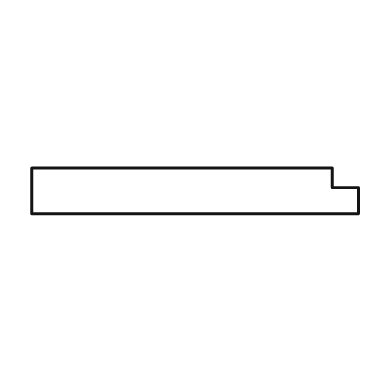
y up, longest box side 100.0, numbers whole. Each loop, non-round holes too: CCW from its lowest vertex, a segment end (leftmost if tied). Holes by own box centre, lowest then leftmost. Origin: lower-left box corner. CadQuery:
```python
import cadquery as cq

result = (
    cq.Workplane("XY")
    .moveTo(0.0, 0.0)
    .lineTo(100.0, 0.0)
    .lineTo(100.0, 8.0)
    .lineTo(92.0, 8.0)
    .lineTo(92.0, 14.0)
    .lineTo(0.0, 14.0)
    .close()
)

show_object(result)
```